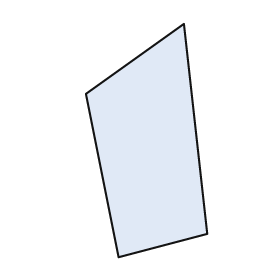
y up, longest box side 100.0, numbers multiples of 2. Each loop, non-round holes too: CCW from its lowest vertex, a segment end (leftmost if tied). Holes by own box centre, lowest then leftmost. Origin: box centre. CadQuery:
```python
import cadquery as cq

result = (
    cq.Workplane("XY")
    .moveTo(-12.0, -50.0)
    .lineTo(26.0, -40.0)
    .lineTo(16.0, 50.0)
    .lineTo(-26.0, 20.0)
    .close()
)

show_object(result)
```